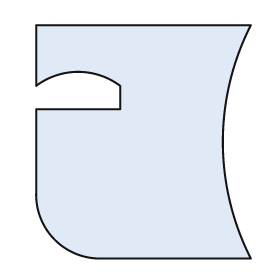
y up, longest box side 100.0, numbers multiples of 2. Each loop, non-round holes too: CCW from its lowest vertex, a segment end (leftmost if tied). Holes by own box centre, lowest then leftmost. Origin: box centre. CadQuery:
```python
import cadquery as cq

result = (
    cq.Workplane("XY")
    .moveTo(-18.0, -50.0)
    .lineTo(46.0, -50.0)
    .threePointArc((34.0, 0.0), (46.0, 50.0))
    .lineTo(-46.0, 50.0)
    .lineTo(-46.0, 24.0)
    .threePointArc((-28.0, 30.0), (-10.0, 24.0))
    .lineTo(-10.0, 14.0)
    .lineTo(-46.0, 14.0)
    .lineTo(-46.0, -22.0)
    .threePointArc((-38.0, -42.0), (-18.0, -50.0))
    .close()
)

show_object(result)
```